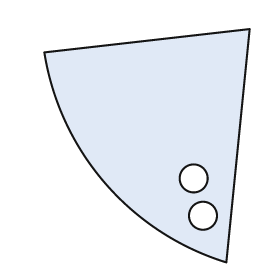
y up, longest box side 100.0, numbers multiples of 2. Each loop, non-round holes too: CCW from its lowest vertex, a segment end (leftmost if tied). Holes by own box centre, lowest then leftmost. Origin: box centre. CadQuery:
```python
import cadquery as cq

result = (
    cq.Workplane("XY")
    .moveTo(34.0, -50.0)
    .lineTo(44.0, 50.0)
    .lineTo(-44.0, 40.0)
    .threePointArc((-18.0, -16.0), (34.0, -50.0))
    .close()
    .moveTo(24.0, -30.0)
    .circle(6.0)
    .moveTo(20.0, -14.0)
    .circle(6.0)
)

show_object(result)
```